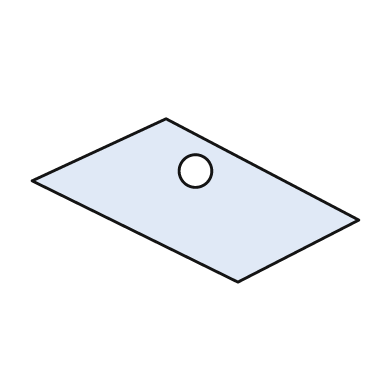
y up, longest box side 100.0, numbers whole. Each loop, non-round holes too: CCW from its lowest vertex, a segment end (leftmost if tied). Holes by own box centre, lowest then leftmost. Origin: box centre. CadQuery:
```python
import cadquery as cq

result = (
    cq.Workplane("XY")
    .moveTo(13.0, -25.0)
    .lineTo(50.0, -6.0)
    .lineTo(-9.0, 25.0)
    .lineTo(-50.0, 6.0)
    .close()
    .moveTo(0.0, 9.0)
    .circle(5.0)
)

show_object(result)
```